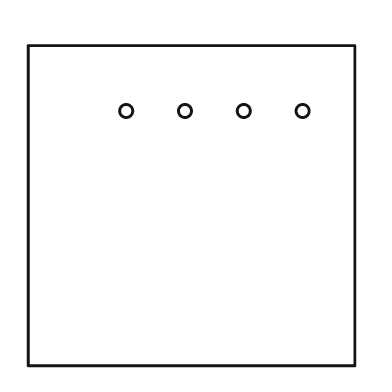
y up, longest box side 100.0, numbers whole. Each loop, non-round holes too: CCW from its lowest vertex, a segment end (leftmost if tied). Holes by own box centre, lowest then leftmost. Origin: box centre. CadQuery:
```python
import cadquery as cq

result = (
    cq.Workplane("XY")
    .moveTo(-50.0, -49.0)
    .lineTo(50.0, -49.0)
    .lineTo(50.0, 49.0)
    .lineTo(-50.0, 49.0)
    .close()
    .moveTo(-20.0, 29.0)
    .circle(2.0)
    .moveTo(-2.0, 29.0)
    .circle(2.0)
    .moveTo(16.0, 29.0)
    .circle(2.0)
    .moveTo(34.0, 29.0)
    .circle(2.0)
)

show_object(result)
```